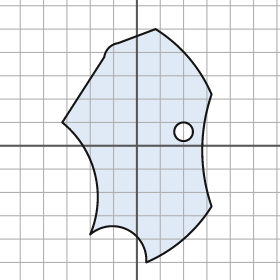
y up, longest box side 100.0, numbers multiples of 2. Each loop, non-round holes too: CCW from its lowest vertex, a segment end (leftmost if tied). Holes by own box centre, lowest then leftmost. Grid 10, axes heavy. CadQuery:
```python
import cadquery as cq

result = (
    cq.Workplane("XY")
    .moveTo(4.0, -50.0)
    .threePointArc((20.0, -40.0), (32.0, -26.0))
    .threePointArc((28.0, -2.0), (32.0, 22.0))
    .threePointArc((22.0, 38.0), (8.0, 50.0))
    .lineTo(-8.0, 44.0)
    .threePointArc((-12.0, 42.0), (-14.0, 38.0))
    .lineTo(-32.0, 10.0)
    .threePointArc((-18.0, -12.0), (-20.0, -38.0))
    .threePointArc((-4.0, -36.0), (4.0, -50.0))
    .close()
    .moveTo(20.0, 6.0)
    .circle(4.0)
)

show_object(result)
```